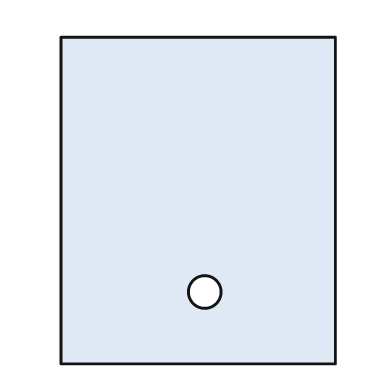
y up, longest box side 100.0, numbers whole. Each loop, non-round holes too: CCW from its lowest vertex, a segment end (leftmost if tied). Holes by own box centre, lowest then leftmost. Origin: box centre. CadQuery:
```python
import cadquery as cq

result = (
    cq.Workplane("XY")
    .moveTo(-42.0, -50.0)
    .lineTo(42.0, -50.0)
    .lineTo(42.0, 50.0)
    .lineTo(-42.0, 50.0)
    .close()
    .moveTo(2.0, -28.0)
    .circle(5.0)
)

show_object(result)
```